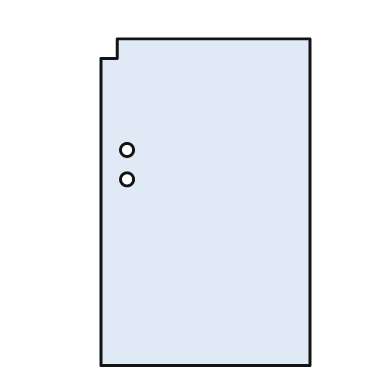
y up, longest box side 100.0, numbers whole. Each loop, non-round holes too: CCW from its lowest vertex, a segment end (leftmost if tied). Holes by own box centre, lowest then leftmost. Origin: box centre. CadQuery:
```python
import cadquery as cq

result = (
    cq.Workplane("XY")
    .moveTo(-32.0, -50.0)
    .lineTo(32.0, -50.0)
    .lineTo(32.0, 50.0)
    .lineTo(-27.0, 50.0)
    .lineTo(-27.0, 44.0)
    .lineTo(-32.0, 44.0)
    .close()
    .moveTo(-24.0, 7.0)
    .circle(2.0)
    .moveTo(-24.0, 16.0)
    .circle(2.0)
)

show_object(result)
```